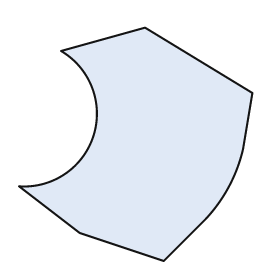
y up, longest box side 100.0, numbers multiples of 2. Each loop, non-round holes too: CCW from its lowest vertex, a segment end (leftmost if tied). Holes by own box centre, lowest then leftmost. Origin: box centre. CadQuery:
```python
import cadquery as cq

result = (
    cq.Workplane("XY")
    .moveTo(12.0, -50.0)
    .lineTo(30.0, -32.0)
    .threePointArc((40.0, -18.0), (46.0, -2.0))
    .lineTo(50.0, 22.0)
    .lineTo(4.0, 50.0)
    .lineTo(-32.0, 40.0)
    .threePointArc((-18.0, 4.0), (-50.0, -18.0))
    .lineTo(-24.0, -38.0)
    .close()
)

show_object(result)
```